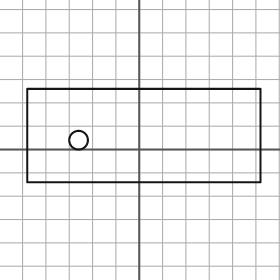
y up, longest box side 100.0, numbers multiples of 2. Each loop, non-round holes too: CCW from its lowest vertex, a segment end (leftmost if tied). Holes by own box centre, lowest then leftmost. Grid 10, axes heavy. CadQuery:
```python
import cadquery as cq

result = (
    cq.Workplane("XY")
    .moveTo(-48.0, -14.0)
    .lineTo(52.0, -14.0)
    .lineTo(52.0, 26.0)
    .lineTo(-48.0, 26.0)
    .close()
    .moveTo(-26.0, 4.0)
    .circle(4.0)
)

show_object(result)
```